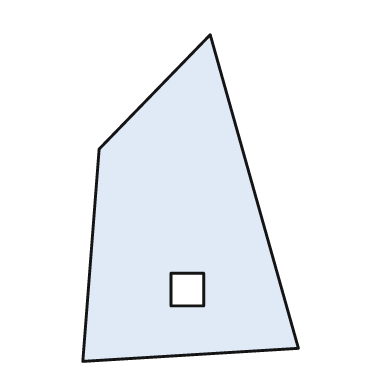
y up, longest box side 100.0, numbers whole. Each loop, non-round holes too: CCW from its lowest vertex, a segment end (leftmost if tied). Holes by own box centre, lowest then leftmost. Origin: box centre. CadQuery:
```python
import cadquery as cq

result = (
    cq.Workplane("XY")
    .moveTo(-33.0, -50.0)
    .lineTo(33.0, -46.0)
    .lineTo(6.0, 50.0)
    .lineTo(-28.0, 15.0)
    .close()
    .moveTo(-6.0, -33.0)
    .lineTo(4.0, -33.0)
    .lineTo(4.0, -23.0)
    .lineTo(-6.0, -23.0)
    .close()
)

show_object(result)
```